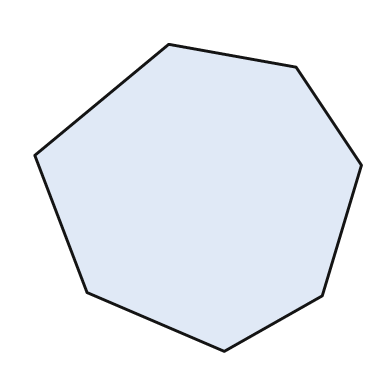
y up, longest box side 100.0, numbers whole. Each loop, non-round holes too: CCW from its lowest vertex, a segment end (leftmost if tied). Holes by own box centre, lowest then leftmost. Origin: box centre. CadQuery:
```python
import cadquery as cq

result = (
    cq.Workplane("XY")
    .moveTo(8.0, -47.0)
    .lineTo(38.0, -30.0)
    .lineTo(50.0, 10.0)
    .lineTo(30.0, 40.0)
    .lineTo(-9.0, 47.0)
    .lineTo(-50.0, 13.0)
    .lineTo(-34.0, -29.0)
    .close()
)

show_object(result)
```